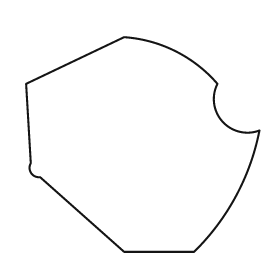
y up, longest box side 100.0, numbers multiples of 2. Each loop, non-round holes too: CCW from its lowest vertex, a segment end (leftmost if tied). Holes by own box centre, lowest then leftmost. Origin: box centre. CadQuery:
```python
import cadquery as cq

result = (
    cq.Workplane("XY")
    .moveTo(-8.0, -46.0)
    .lineTo(22.0, -46.0)
    .threePointArc((40.0, -22.0), (50.0, 6.0))
    .threePointArc((34.0, 10.0), (32.0, 26.0))
    .threePointArc((14.0, 40.0), (-8.0, 46.0))
    .lineTo(-50.0, 26.0)
    .lineTo(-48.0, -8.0)
    .threePointArc((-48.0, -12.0), (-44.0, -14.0))
    .close()
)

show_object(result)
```